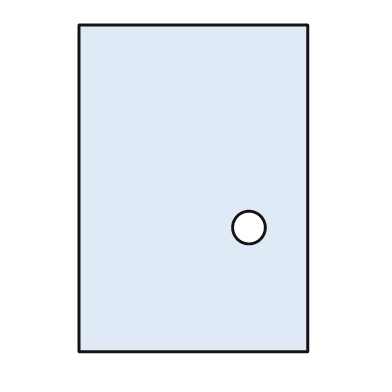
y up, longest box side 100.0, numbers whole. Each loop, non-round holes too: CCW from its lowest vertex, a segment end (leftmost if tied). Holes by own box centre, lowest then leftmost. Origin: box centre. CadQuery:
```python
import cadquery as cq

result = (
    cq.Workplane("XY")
    .moveTo(-35.0, -50.0)
    .lineTo(35.0, -50.0)
    .lineTo(35.0, 50.0)
    .lineTo(-35.0, 50.0)
    .close()
    .moveTo(17.0, -12.0)
    .circle(5.0)
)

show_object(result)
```